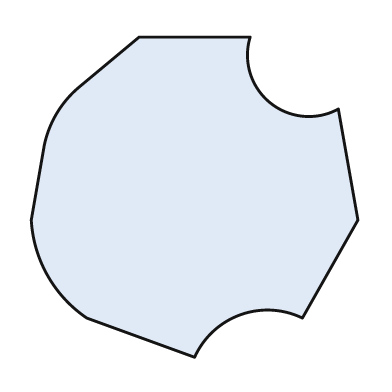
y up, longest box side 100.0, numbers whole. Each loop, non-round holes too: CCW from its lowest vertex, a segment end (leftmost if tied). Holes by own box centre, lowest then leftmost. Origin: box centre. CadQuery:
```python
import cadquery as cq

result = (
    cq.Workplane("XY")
    .moveTo(0.0, -49.0)
    .threePointArc((14.0, -36.0), (33.0, -37.0))
    .lineTo(50.0, -7.0)
    .lineTo(44.0, 27.0)
    .threePointArc((23.0, 29.0), (17.0, 49.0))
    .lineTo(-17.0, 49.0)
    .lineTo(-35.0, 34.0)
    .threePointArc((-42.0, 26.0), (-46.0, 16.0))
    .lineTo(-50.0, -7.0)
    .threePointArc((-45.0, -24.0), (-33.0, -37.0))
    .close()
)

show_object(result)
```